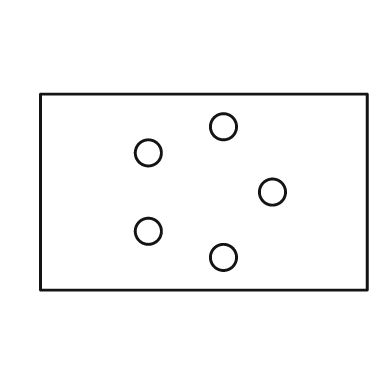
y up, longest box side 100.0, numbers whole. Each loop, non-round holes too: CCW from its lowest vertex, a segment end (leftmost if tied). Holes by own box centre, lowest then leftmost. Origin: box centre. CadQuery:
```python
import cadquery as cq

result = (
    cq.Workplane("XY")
    .moveTo(-50.0, -30.0)
    .lineTo(50.0, -30.0)
    .lineTo(50.0, 30.0)
    .lineTo(-50.0, 30.0)
    .close()
    .moveTo(6.0, -20.0)
    .circle(4.0)
    .moveTo(-17.0, -12.0)
    .circle(4.0)
    .moveTo(21.0, 0.0)
    .circle(4.0)
    .moveTo(-17.0, 12.0)
    .circle(4.0)
    .moveTo(6.0, 20.0)
    .circle(4.0)
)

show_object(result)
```